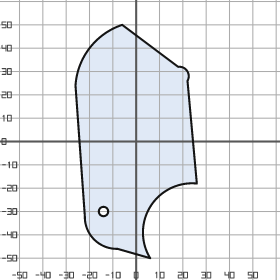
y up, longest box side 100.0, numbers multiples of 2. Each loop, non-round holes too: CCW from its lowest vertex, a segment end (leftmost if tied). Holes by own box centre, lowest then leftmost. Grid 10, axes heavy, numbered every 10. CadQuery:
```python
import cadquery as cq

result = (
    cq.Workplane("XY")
    .moveTo(6.0, -50.0)
    .threePointArc((6.0, -28.0), (26.0, -18.0))
    .lineTo(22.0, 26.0)
    .threePointArc((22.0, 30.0), (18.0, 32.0))
    .lineTo(-6.0, 50.0)
    .threePointArc((-20.0, 40.0), (-26.0, 24.0))
    .lineTo(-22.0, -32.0)
    .threePointArc((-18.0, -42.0), (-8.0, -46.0))
    .close()
    .moveTo(-14.0, -30.0)
    .circle(2.0)
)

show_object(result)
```